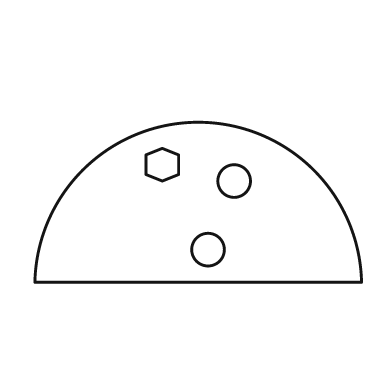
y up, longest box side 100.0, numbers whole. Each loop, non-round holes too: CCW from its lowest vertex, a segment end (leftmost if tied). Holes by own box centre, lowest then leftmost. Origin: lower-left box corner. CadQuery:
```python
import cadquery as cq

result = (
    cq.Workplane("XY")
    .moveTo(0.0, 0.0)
    .lineTo(100.0, 0.0)
    .threePointArc((50.0, 49.0), (0.0, 0.0))
    .close()
    .moveTo(53.0, 10.0)
    .circle(5.0)
    .moveTo(61.0, 31.0)
    .circle(5.0)
    .moveTo(39.0, 31.0)
    .lineTo(44.0, 33.0)
    .lineTo(44.0, 39.0)
    .lineTo(39.0, 41.0)
    .lineTo(34.0, 39.0)
    .lineTo(34.0, 33.0)
    .close()
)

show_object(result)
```